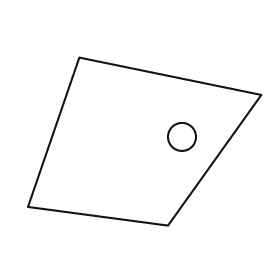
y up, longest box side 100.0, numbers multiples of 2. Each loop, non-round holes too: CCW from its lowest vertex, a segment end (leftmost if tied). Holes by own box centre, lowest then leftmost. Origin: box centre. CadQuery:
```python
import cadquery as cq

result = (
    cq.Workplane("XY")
    .moveTo(10.0, -36.0)
    .lineTo(50.0, 20.0)
    .lineTo(-28.0, 36.0)
    .lineTo(-50.0, -28.0)
    .close()
    .moveTo(16.0, 2.0)
    .circle(6.0)
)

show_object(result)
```